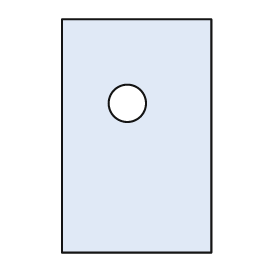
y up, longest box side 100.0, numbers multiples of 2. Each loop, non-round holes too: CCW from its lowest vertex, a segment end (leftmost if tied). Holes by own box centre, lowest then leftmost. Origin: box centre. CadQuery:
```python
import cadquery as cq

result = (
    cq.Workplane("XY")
    .moveTo(-32.0, -50.0)
    .lineTo(32.0, -50.0)
    .lineTo(32.0, 50.0)
    .lineTo(-32.0, 50.0)
    .close()
    .moveTo(-4.0, 14.0)
    .circle(8.0)
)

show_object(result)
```